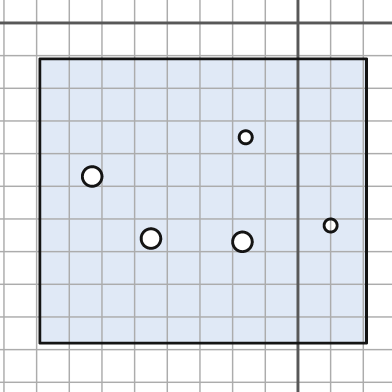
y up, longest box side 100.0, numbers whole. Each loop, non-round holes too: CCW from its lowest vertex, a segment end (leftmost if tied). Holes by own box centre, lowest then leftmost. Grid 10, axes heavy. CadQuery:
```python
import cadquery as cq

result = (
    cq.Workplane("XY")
    .moveTo(-79.0, -98.0)
    .lineTo(21.0, -98.0)
    .lineTo(21.0, -11.0)
    .lineTo(-79.0, -11.0)
    .close()
    .moveTo(-17.0, -67.0)
    .circle(3.0)
    .moveTo(-45.0, -66.0)
    .circle(3.0)
    .moveTo(10.0, -62.0)
    .circle(2.0)
    .moveTo(-63.0, -47.0)
    .circle(3.0)
    .moveTo(-16.0, -35.0)
    .circle(2.0)
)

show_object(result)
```